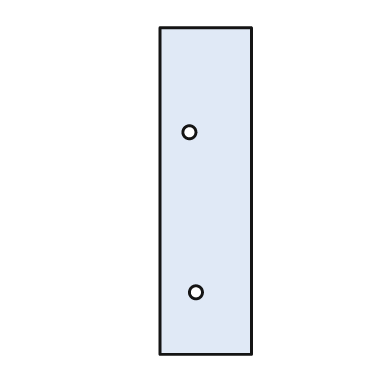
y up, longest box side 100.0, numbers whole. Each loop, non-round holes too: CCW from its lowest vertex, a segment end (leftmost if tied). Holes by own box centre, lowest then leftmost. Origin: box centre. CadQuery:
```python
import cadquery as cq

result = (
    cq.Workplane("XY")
    .moveTo(-14.0, -50.0)
    .lineTo(14.0, -50.0)
    .lineTo(14.0, 50.0)
    .lineTo(-14.0, 50.0)
    .close()
    .moveTo(-3.0, -31.0)
    .circle(2.0)
    .moveTo(-5.0, 18.0)
    .circle(2.0)
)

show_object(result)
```